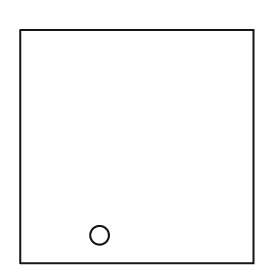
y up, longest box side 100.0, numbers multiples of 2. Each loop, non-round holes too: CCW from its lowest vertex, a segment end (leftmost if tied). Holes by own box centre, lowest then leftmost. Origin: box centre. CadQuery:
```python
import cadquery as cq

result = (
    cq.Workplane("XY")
    .moveTo(-50.0, -50.0)
    .lineTo(50.0, -50.0)
    .lineTo(50.0, 50.0)
    .lineTo(-50.0, 50.0)
    .close()
    .moveTo(-16.0, -38.0)
    .circle(4.0)
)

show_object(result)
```